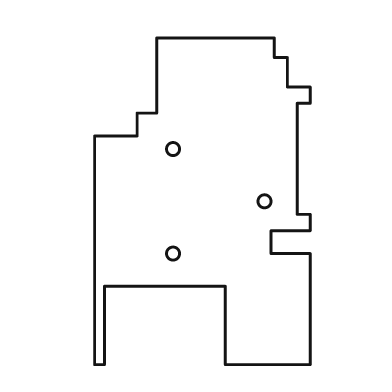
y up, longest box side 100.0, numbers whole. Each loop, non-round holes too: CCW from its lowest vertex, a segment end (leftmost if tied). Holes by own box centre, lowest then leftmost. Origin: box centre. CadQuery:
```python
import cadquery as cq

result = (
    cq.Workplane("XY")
    .moveTo(-33.0, -50.0)
    .lineTo(-30.0, -50.0)
    .lineTo(-30.0, -26.0)
    .lineTo(7.0, -26.0)
    .lineTo(7.0, -50.0)
    .lineTo(33.0, -50.0)
    .lineTo(33.0, -16.0)
    .lineTo(21.0, -16.0)
    .lineTo(21.0, -9.0)
    .lineTo(33.0, -9.0)
    .lineTo(33.0, -4.0)
    .lineTo(29.0, -4.0)
    .lineTo(29.0, 30.0)
    .lineTo(33.0, 30.0)
    .lineTo(33.0, 35.0)
    .lineTo(26.0, 35.0)
    .lineTo(26.0, 44.0)
    .lineTo(22.0, 44.0)
    .lineTo(22.0, 50.0)
    .lineTo(-14.0, 50.0)
    .lineTo(-14.0, 27.0)
    .lineTo(-20.0, 27.0)
    .lineTo(-20.0, 20.0)
    .lineTo(-33.0, 20.0)
    .close()
    .moveTo(-9.0, -16.0)
    .circle(2.0)
    .moveTo(19.0, 0.0)
    .circle(2.0)
    .moveTo(-9.0, 16.0)
    .circle(2.0)
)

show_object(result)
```